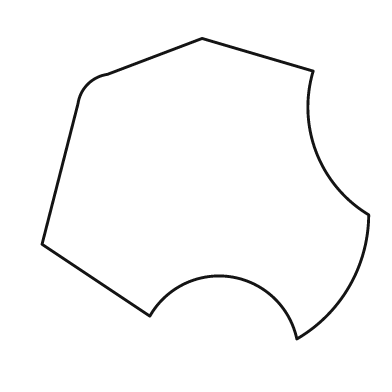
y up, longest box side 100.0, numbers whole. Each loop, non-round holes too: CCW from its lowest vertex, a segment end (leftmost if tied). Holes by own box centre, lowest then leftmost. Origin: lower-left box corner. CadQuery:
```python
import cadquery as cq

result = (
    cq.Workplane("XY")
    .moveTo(78.0, 0.0)
    .threePointArc((94.0, 16.0), (100.0, 38.0))
    .threePointArc((84.0, 57.0), (83.0, 82.0))
    .lineTo(49.0, 92.0)
    .lineTo(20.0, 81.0)
    .threePointArc((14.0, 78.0), (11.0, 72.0))
    .lineTo(0.0, 29.0)
    .lineTo(33.0, 7.0)
    .threePointArc((58.0, 19.0), (78.0, 0.0))
    .close()
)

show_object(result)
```